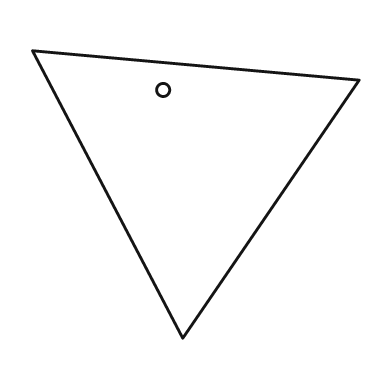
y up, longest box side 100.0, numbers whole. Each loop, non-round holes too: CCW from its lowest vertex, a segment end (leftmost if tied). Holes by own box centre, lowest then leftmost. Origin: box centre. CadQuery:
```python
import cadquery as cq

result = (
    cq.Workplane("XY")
    .moveTo(-4.0, -44.0)
    .lineTo(50.0, 35.0)
    .lineTo(-50.0, 44.0)
    .close()
    .moveTo(-10.0, 32.0)
    .circle(2.0)
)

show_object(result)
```